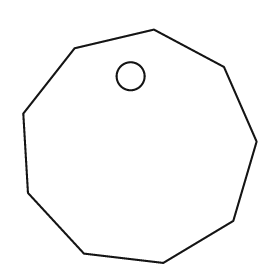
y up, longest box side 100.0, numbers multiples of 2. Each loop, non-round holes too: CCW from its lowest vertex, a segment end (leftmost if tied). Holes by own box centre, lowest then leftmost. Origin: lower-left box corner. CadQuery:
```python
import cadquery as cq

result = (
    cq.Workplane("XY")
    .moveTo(60.0, 0.0)
    .lineTo(90.0, 18.0)
    .lineTo(100.0, 52.0)
    .lineTo(86.0, 84.0)
    .lineTo(56.0, 100.0)
    .lineTo(22.0, 92.0)
    .lineTo(0.0, 64.0)
    .lineTo(2.0, 30.0)
    .lineTo(26.0, 4.0)
    .close()
    .moveTo(46.0, 80.0)
    .circle(6.0)
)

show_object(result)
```